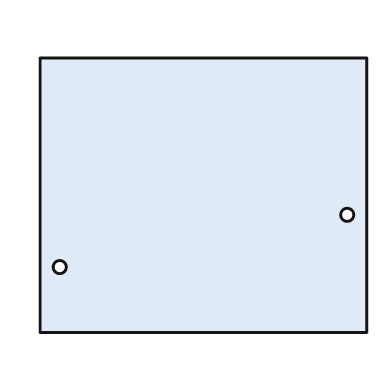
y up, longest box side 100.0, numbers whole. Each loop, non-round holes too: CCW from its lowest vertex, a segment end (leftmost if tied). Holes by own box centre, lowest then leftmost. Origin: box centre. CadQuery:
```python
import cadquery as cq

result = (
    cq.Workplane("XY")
    .moveTo(-50.0, -42.0)
    .lineTo(50.0, -42.0)
    .lineTo(50.0, 42.0)
    .lineTo(-50.0, 42.0)
    .close()
    .moveTo(-44.0, -22.0)
    .circle(2.0)
    .moveTo(44.0, -6.0)
    .circle(2.0)
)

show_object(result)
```